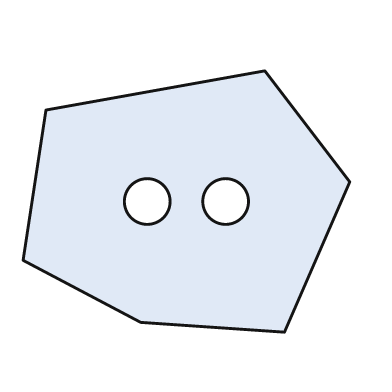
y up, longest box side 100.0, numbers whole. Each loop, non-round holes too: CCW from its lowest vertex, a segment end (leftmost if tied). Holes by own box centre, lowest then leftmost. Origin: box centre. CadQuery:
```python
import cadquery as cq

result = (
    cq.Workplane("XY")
    .moveTo(30.0, -40.0)
    .lineTo(50.0, 6.0)
    .lineTo(24.0, 40.0)
    .lineTo(-43.0, 28.0)
    .lineTo(-50.0, -18.0)
    .lineTo(-14.0, -37.0)
    .close()
    .moveTo(-12.0, 0.0)
    .circle(7.0)
    .moveTo(12.0, 0.0)
    .circle(7.0)
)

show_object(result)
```